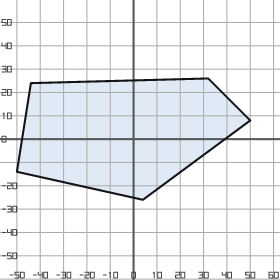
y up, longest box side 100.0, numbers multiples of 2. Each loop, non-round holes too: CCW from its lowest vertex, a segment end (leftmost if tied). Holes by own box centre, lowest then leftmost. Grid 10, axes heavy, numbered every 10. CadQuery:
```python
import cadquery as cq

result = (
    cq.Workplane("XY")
    .moveTo(4.0, -26.0)
    .lineTo(50.0, 8.0)
    .lineTo(32.0, 26.0)
    .lineTo(-44.0, 24.0)
    .lineTo(-50.0, -14.0)
    .close()
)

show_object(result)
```